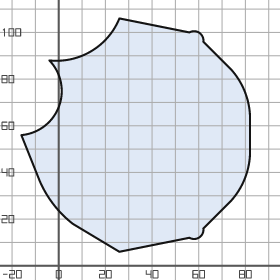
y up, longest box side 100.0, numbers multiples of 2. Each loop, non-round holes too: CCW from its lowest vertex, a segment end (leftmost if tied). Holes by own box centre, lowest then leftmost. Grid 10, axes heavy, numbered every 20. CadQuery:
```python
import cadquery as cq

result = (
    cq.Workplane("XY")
    .moveTo(26.0, 6.0)
    .lineTo(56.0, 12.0)
    .threePointArc((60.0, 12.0), (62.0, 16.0))
    .lineTo(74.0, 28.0)
    .threePointArc((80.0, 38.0), (82.0, 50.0))
    .lineTo(82.0, 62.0)
    .threePointArc((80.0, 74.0), (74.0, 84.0))
    .lineTo(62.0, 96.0)
    .threePointArc((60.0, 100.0), (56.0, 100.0))
    .lineTo(26.0, 106.0)
    .threePointArc((14.0, 92.0), (-4.0, 88.0))
    .threePointArc((0.0, 68.0), (-16.0, 56.0))
    .lineTo(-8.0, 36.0)
    .threePointArc((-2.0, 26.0), (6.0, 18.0))
    .close()
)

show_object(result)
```